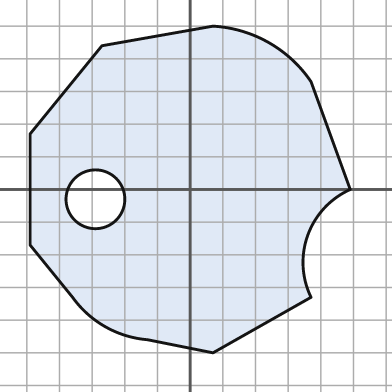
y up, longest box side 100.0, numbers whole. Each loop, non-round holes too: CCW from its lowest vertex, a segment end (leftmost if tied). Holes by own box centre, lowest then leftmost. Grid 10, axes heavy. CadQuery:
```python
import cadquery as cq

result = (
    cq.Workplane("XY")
    .moveTo(7.0, -50.0)
    .lineTo(37.0, -33.0)
    .threePointArc((36.0, -14.0), (49.0, 0.0))
    .lineTo(37.0, 33.0)
    .threePointArc((24.0, 45.0), (7.0, 50.0))
    .lineTo(-27.0, 44.0)
    .lineTo(-49.0, 17.0)
    .lineTo(-49.0, -17.0)
    .lineTo(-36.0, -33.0)
    .threePointArc((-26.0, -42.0), (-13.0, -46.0))
    .close()
    .moveTo(-29.0, -3.0)
    .circle(9.0)
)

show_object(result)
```